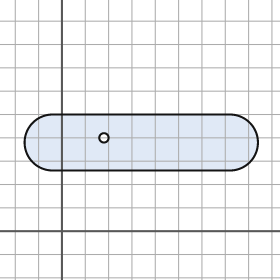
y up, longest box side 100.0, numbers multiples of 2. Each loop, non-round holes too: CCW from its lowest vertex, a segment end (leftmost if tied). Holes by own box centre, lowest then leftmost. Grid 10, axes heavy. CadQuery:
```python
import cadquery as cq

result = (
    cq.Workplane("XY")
    .moveTo(-4.0, 26.0)
    .lineTo(72.0, 26.0)
    .threePointArc((84.0, 38.0), (72.0, 50.0))
    .lineTo(-4.0, 50.0)
    .threePointArc((-16.0, 38.0), (-4.0, 26.0))
    .close()
    .moveTo(18.0, 40.0)
    .circle(2.0)
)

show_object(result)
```